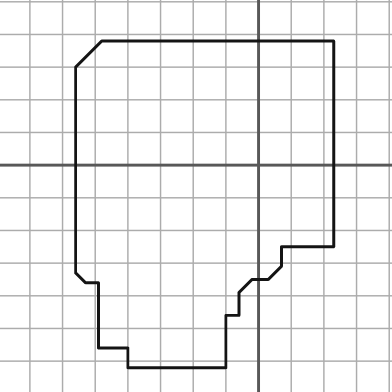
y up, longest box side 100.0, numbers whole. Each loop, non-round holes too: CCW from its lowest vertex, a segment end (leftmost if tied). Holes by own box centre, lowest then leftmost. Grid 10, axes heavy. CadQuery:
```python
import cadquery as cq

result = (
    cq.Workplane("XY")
    .moveTo(-40.0, -62.0)
    .lineTo(-10.0, -62.0)
    .lineTo(-10.0, -46.0)
    .lineTo(-6.0, -46.0)
    .lineTo(-6.0, -39.0)
    .lineTo(-2.0, -35.0)
    .lineTo(3.0, -35.0)
    .lineTo(7.0, -31.0)
    .lineTo(7.0, -25.0)
    .lineTo(23.0, -25.0)
    .lineTo(23.0, 38.0)
    .lineTo(-48.0, 38.0)
    .lineTo(-56.0, 30.0)
    .lineTo(-56.0, -33.0)
    .lineTo(-53.0, -36.0)
    .lineTo(-49.0, -36.0)
    .lineTo(-49.0, -56.0)
    .lineTo(-40.0, -56.0)
    .close()
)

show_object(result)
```